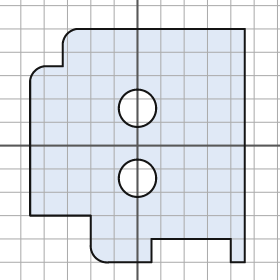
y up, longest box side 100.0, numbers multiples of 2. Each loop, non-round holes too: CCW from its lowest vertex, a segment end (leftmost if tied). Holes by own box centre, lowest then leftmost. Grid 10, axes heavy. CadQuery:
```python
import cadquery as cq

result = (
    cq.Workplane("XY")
    .moveTo(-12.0, -50.0)
    .lineTo(6.0, -50.0)
    .lineTo(6.0, -40.0)
    .lineTo(40.0, -40.0)
    .lineTo(40.0, -50.0)
    .lineTo(46.0, -50.0)
    .lineTo(46.0, 50.0)
    .lineTo(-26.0, 50.0)
    .threePointArc((-30.0, 48.0), (-32.0, 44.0))
    .lineTo(-32.0, 34.0)
    .lineTo(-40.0, 34.0)
    .threePointArc((-44.0, 32.0), (-46.0, 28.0))
    .lineTo(-46.0, -30.0)
    .lineTo(-20.0, -30.0)
    .lineTo(-20.0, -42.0)
    .threePointArc((-18.0, -48.0), (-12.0, -50.0))
    .close()
    .moveTo(0.0, -14.0)
    .circle(8.0)
    .moveTo(0.0, 16.0)
    .circle(8.0)
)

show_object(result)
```